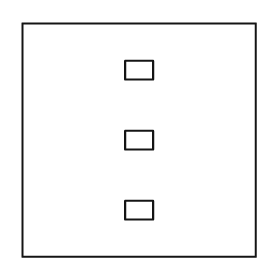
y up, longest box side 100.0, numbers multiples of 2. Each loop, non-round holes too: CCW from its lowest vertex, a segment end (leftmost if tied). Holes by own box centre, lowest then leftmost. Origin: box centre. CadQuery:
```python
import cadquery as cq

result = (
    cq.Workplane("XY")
    .moveTo(-50.0, -50.0)
    .lineTo(50.0, -50.0)
    .lineTo(50.0, 50.0)
    .lineTo(-50.0, 50.0)
    .close()
    .moveTo(-6.0, -34.0)
    .lineTo(6.0, -34.0)
    .lineTo(6.0, -26.0)
    .lineTo(-6.0, -26.0)
    .close()
    .moveTo(-6.0, -4.0)
    .lineTo(6.0, -4.0)
    .lineTo(6.0, 4.0)
    .lineTo(-6.0, 4.0)
    .close()
    .moveTo(-6.0, 26.0)
    .lineTo(6.0, 26.0)
    .lineTo(6.0, 34.0)
    .lineTo(-6.0, 34.0)
    .close()
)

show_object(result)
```